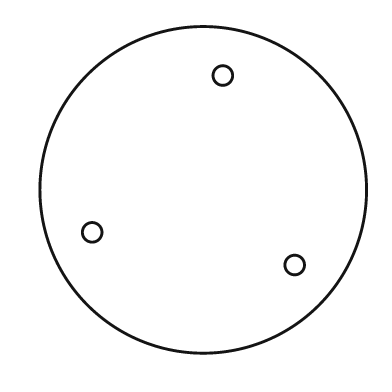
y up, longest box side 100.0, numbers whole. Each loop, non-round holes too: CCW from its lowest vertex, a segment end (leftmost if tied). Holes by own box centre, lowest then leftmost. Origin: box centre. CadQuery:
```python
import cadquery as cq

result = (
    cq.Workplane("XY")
    .moveTo(0.0, 0.0)
    .circle(50.0)
    .moveTo(28.0, -23.0)
    .circle(3.0)
    .moveTo(-34.0, -13.0)
    .circle(3.0)
    .moveTo(6.0, 35.0)
    .circle(3.0)
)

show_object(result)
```